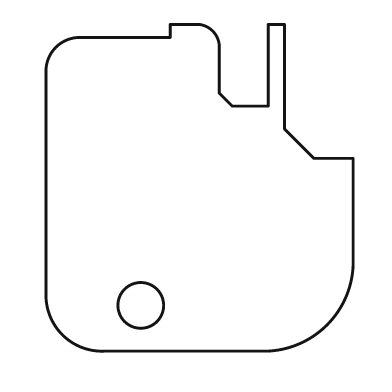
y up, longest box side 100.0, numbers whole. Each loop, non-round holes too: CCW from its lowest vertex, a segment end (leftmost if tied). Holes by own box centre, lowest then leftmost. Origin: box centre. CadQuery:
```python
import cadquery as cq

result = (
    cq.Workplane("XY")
    .moveTo(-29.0, -50.0)
    .lineTo(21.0, -50.0)
    .threePointArc((39.0, -42.0), (47.0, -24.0))
    .lineTo(47.0, 9.0)
    .lineTo(35.0, 9.0)
    .lineTo(26.0, 18.0)
    .lineTo(26.0, 50.0)
    .lineTo(21.0, 50.0)
    .lineTo(21.0, 25.0)
    .lineTo(10.0, 25.0)
    .lineTo(6.0, 29.0)
    .lineTo(6.0, 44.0)
    .threePointArc((4.0, 48.0), (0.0, 50.0))
    .lineTo(-9.0, 50.0)
    .lineTo(-9.0, 46.0)
    .lineTo(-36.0, 46.0)
    .threePointArc((-44.0, 43.0), (-47.0, 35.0))
    .lineTo(-47.0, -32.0)
    .threePointArc((-42.0, -45.0), (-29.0, -50.0))
    .close()
    .moveTo(-18.0, -36.0)
    .circle(7.0)
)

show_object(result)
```